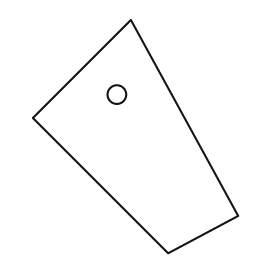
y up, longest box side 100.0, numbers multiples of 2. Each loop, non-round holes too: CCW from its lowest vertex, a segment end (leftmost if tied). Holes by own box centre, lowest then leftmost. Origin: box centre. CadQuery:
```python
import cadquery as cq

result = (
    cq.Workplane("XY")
    .moveTo(14.0, -50.0)
    .lineTo(44.0, -34.0)
    .lineTo(-2.0, 50.0)
    .lineTo(-44.0, 8.0)
    .close()
    .moveTo(-8.0, 18.0)
    .circle(4.0)
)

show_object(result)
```